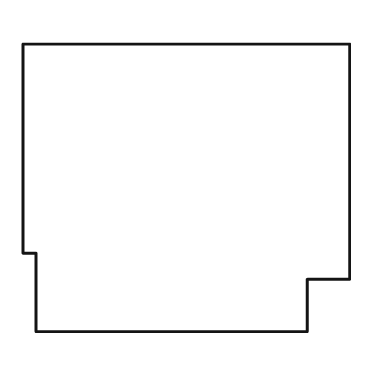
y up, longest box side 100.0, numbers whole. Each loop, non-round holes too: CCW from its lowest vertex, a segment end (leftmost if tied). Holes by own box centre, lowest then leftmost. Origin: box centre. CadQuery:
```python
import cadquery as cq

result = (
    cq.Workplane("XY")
    .moveTo(-46.0, -44.0)
    .lineTo(37.0, -44.0)
    .lineTo(37.0, -28.0)
    .lineTo(50.0, -28.0)
    .lineTo(50.0, 44.0)
    .lineTo(-50.0, 44.0)
    .lineTo(-50.0, -20.0)
    .lineTo(-46.0, -20.0)
    .close()
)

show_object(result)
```